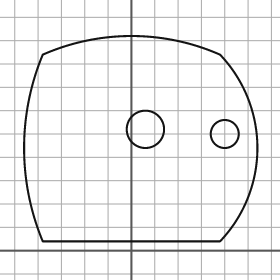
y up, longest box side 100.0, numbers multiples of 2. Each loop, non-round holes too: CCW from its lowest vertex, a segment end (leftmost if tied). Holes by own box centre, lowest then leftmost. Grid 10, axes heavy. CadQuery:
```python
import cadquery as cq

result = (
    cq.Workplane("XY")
    .moveTo(-38.0, 4.0)
    .lineTo(38.0, 4.0)
    .threePointArc((54.0, 44.0), (38.0, 84.0))
    .threePointArc((0.0, 92.0), (-38.0, 84.0))
    .threePointArc((-46.0, 44.0), (-38.0, 4.0))
    .close()
    .moveTo(40.0, 50.0)
    .circle(6.0)
    .moveTo(6.0, 52.0)
    .circle(8.0)
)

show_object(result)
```